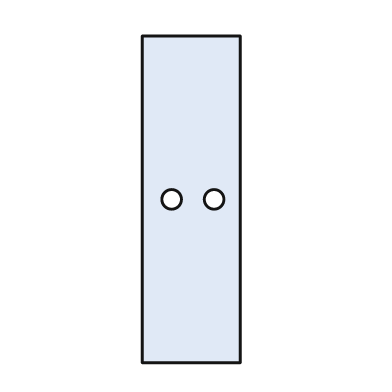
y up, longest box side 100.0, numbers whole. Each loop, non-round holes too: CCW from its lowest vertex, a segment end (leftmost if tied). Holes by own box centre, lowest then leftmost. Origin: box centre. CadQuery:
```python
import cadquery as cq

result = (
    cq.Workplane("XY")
    .moveTo(-15.0, -50.0)
    .lineTo(15.0, -50.0)
    .lineTo(15.0, 50.0)
    .lineTo(-15.0, 50.0)
    .close()
    .moveTo(-6.0, 0.0)
    .circle(3.0)
    .moveTo(7.0, 0.0)
    .circle(3.0)
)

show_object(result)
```